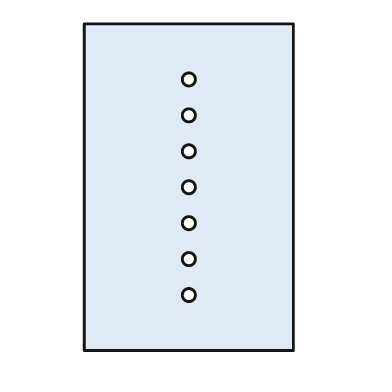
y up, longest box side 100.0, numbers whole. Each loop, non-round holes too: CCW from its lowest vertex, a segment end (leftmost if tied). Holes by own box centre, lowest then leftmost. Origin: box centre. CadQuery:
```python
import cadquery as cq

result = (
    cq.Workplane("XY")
    .moveTo(-32.0, -50.0)
    .lineTo(32.0, -50.0)
    .lineTo(32.0, 50.0)
    .lineTo(-32.0, 50.0)
    .close()
    .moveTo(0.0, -33.0)
    .circle(2.0)
    .moveTo(0.0, -22.0)
    .circle(2.0)
    .moveTo(0.0, -11.0)
    .circle(2.0)
    .moveTo(0.0, 0.0)
    .circle(2.0)
    .moveTo(0.0, 11.0)
    .circle(2.0)
    .moveTo(0.0, 22.0)
    .circle(2.0)
    .moveTo(0.0, 33.0)
    .circle(2.0)
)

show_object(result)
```